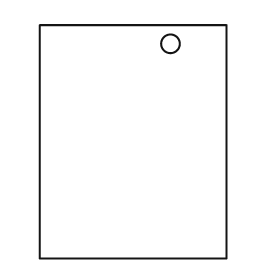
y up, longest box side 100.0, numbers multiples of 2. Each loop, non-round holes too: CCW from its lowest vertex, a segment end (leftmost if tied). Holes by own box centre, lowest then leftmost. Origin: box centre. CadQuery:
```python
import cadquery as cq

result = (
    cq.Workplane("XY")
    .moveTo(-40.0, -50.0)
    .lineTo(40.0, -50.0)
    .lineTo(40.0, 50.0)
    .lineTo(-40.0, 50.0)
    .close()
    .moveTo(16.0, 42.0)
    .circle(4.0)
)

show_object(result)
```